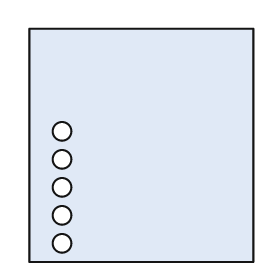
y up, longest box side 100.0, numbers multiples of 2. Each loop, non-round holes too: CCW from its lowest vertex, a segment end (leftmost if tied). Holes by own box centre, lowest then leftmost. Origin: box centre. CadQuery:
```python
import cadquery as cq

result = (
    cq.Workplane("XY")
    .moveTo(-48.0, -50.0)
    .lineTo(48.0, -50.0)
    .lineTo(48.0, 50.0)
    .lineTo(-48.0, 50.0)
    .close()
    .moveTo(-34.0, -42.0)
    .circle(4.0)
    .moveTo(-34.0, -30.0)
    .circle(4.0)
    .moveTo(-34.0, -18.0)
    .circle(4.0)
    .moveTo(-34.0, -6.0)
    .circle(4.0)
    .moveTo(-34.0, 6.0)
    .circle(4.0)
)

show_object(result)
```